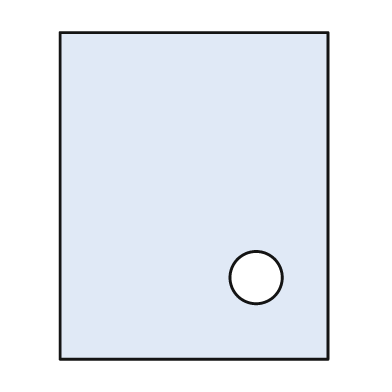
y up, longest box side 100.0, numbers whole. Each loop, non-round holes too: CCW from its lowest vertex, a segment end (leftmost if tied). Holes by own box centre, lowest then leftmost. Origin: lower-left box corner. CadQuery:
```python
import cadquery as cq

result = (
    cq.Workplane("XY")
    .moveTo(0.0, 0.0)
    .lineTo(82.0, 0.0)
    .lineTo(82.0, 100.0)
    .lineTo(0.0, 100.0)
    .close()
    .moveTo(60.0, 25.0)
    .circle(8.0)
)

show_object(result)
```